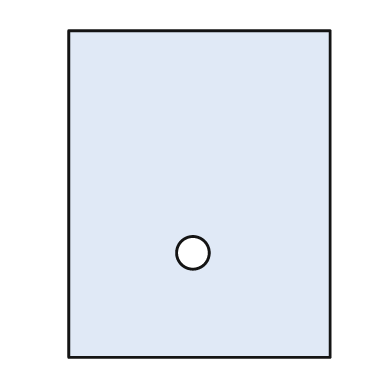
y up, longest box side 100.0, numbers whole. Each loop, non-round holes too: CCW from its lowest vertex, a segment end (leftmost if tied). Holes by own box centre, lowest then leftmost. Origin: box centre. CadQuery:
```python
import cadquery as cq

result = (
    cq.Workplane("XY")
    .moveTo(-40.0, -50.0)
    .lineTo(40.0, -50.0)
    .lineTo(40.0, 50.0)
    .lineTo(-40.0, 50.0)
    .close()
    .moveTo(-2.0, -18.0)
    .circle(5.0)
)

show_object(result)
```